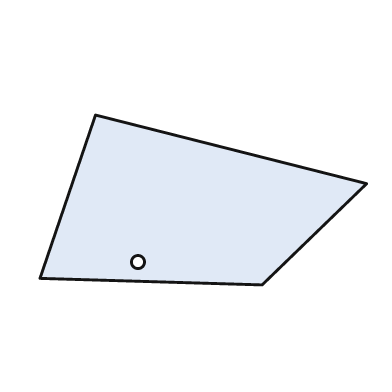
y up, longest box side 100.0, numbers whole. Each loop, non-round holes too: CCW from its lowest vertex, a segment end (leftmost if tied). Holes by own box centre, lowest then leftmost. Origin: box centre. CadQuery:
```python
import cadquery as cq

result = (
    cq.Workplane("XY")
    .moveTo(18.0, -26.0)
    .lineTo(50.0, 5.0)
    .lineTo(-33.0, 26.0)
    .lineTo(-50.0, -24.0)
    .close()
    .moveTo(-20.0, -19.0)
    .circle(2.0)
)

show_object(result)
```